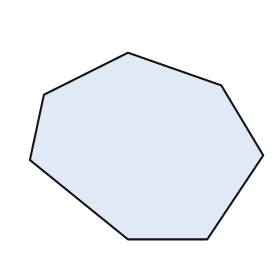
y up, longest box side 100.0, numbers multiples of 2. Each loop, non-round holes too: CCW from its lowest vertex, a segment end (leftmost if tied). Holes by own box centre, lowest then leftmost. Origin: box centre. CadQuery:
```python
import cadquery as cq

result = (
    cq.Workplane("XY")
    .moveTo(-8.0, -40.0)
    .lineTo(26.0, -40.0)
    .lineTo(50.0, -4.0)
    .lineTo(32.0, 26.0)
    .lineTo(-8.0, 40.0)
    .lineTo(-44.0, 22.0)
    .lineTo(-50.0, -6.0)
    .close()
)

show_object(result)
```